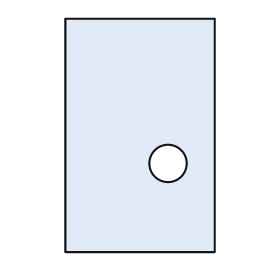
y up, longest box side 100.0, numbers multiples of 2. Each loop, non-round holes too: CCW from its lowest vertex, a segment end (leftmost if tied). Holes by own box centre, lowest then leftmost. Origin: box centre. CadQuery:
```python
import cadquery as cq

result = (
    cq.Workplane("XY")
    .moveTo(-32.0, -50.0)
    .lineTo(32.0, -50.0)
    .lineTo(32.0, 50.0)
    .lineTo(-32.0, 50.0)
    .close()
    .moveTo(12.0, -12.0)
    .circle(8.0)
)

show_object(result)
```